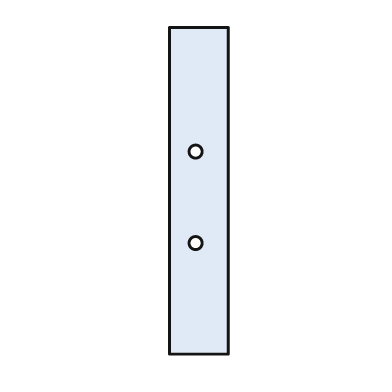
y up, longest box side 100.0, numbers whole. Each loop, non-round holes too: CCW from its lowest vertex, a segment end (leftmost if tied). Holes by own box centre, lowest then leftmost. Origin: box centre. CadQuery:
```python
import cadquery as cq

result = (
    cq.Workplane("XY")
    .moveTo(-9.0, -50.0)
    .lineTo(9.0, -50.0)
    .lineTo(9.0, 50.0)
    .lineTo(-9.0, 50.0)
    .close()
    .moveTo(-1.0, -16.0)
    .circle(2.0)
    .moveTo(-1.0, 12.0)
    .circle(2.0)
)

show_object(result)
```